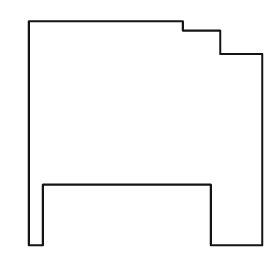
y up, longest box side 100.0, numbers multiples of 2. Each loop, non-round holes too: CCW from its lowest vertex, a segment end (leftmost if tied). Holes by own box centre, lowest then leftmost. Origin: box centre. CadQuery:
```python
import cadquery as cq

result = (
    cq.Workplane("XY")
    .moveTo(-50.0, -48.0)
    .lineTo(-44.0, -48.0)
    .lineTo(-44.0, -22.0)
    .lineTo(28.0, -22.0)
    .lineTo(28.0, -48.0)
    .lineTo(50.0, -48.0)
    .lineTo(50.0, 34.0)
    .lineTo(32.0, 34.0)
    .lineTo(32.0, 44.0)
    .lineTo(16.0, 44.0)
    .lineTo(16.0, 48.0)
    .lineTo(-50.0, 48.0)
    .close()
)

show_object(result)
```